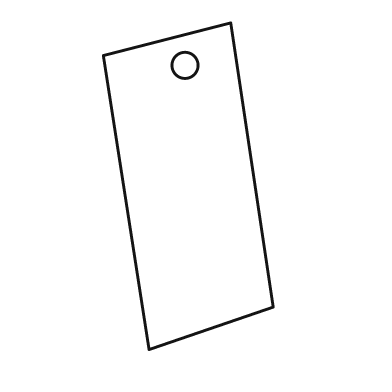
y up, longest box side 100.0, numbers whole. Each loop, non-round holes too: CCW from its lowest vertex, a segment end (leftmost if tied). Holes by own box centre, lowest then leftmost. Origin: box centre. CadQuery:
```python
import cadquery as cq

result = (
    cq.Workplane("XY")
    .moveTo(-12.0, -50.0)
    .lineTo(26.0, -37.0)
    .lineTo(13.0, 50.0)
    .lineTo(-26.0, 40.0)
    .close()
    .moveTo(-1.0, 37.0)
    .circle(4.0)
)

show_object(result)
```